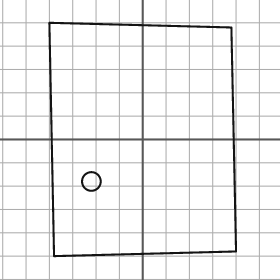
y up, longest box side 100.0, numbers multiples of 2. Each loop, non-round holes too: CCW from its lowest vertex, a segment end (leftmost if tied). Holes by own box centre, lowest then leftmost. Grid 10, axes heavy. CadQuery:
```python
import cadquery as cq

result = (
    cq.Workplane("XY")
    .moveTo(-38.0, -50.0)
    .lineTo(40.0, -48.0)
    .lineTo(38.0, 48.0)
    .lineTo(-40.0, 50.0)
    .close()
    .moveTo(-22.0, -18.0)
    .circle(4.0)
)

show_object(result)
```